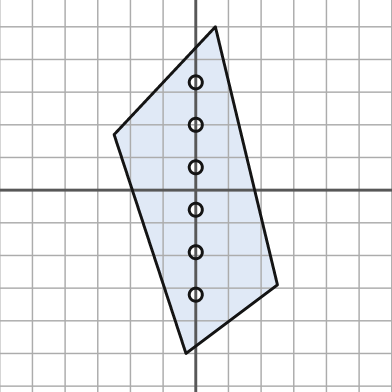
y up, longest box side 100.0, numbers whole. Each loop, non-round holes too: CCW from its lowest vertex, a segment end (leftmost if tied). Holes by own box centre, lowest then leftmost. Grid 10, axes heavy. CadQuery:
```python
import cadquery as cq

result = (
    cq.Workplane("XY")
    .moveTo(-3.0, -50.0)
    .lineTo(25.0, -29.0)
    .lineTo(6.0, 50.0)
    .lineTo(-25.0, 17.0)
    .close()
    .moveTo(0.0, -32.0)
    .circle(2.0)
    .moveTo(0.0, -19.0)
    .circle(2.0)
    .moveTo(0.0, -6.0)
    .circle(2.0)
    .moveTo(0.0, 7.0)
    .circle(2.0)
    .moveTo(0.0, 20.0)
    .circle(2.0)
    .moveTo(0.0, 33.0)
    .circle(2.0)
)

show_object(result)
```